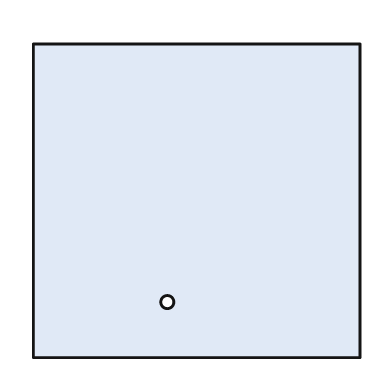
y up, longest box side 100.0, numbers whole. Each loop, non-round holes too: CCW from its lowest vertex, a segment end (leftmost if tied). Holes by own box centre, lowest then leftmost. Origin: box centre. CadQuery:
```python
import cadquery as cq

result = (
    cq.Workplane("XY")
    .moveTo(-50.0, -48.0)
    .lineTo(50.0, -48.0)
    .lineTo(50.0, 48.0)
    .lineTo(-50.0, 48.0)
    .close()
    .moveTo(-9.0, -31.0)
    .circle(2.0)
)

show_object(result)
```